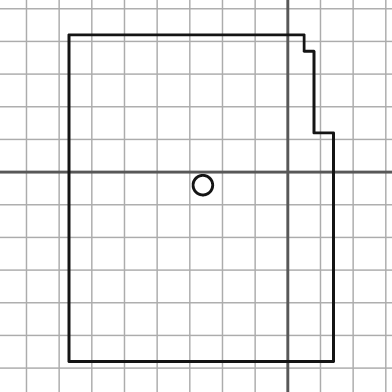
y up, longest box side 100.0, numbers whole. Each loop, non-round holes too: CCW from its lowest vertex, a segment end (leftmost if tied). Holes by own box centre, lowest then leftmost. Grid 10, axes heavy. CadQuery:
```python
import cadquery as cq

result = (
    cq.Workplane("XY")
    .moveTo(-67.0, -58.0)
    .lineTo(14.0, -58.0)
    .lineTo(14.0, 12.0)
    .lineTo(8.0, 12.0)
    .lineTo(8.0, 37.0)
    .lineTo(5.0, 37.0)
    .lineTo(5.0, 42.0)
    .lineTo(-67.0, 42.0)
    .close()
    .moveTo(-26.0, -4.0)
    .circle(3.0)
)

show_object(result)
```